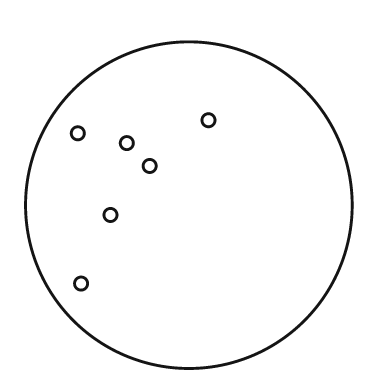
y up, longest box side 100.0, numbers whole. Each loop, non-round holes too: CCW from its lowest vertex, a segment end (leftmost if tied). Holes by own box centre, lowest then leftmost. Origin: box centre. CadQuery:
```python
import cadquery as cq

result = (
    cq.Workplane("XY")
    .moveTo(0.0, 0.0)
    .circle(50.0)
    .moveTo(-33.0, -24.0)
    .circle(2.0)
    .moveTo(-24.0, -3.0)
    .circle(2.0)
    .moveTo(-12.0, 12.0)
    .circle(2.0)
    .moveTo(-19.0, 19.0)
    .circle(2.0)
    .moveTo(-34.0, 22.0)
    .circle(2.0)
    .moveTo(6.0, 26.0)
    .circle(2.0)
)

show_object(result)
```